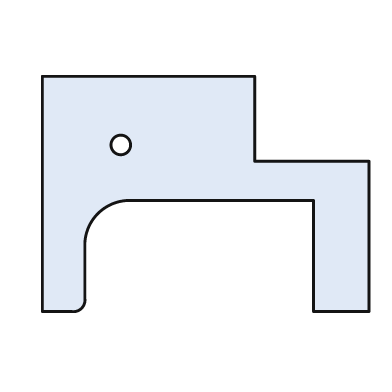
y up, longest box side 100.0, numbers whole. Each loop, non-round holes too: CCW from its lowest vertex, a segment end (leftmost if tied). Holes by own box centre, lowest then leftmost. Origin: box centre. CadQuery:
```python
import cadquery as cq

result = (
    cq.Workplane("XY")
    .moveTo(-50.0, -36.0)
    .lineTo(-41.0, -36.0)
    .threePointArc((-38.0, -35.0), (-37.0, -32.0))
    .lineTo(-37.0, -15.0)
    .threePointArc((-33.0, -6.0), (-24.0, -2.0))
    .lineTo(33.0, -2.0)
    .lineTo(33.0, -36.0)
    .lineTo(50.0, -36.0)
    .lineTo(50.0, 10.0)
    .lineTo(15.0, 10.0)
    .lineTo(15.0, 36.0)
    .lineTo(-50.0, 36.0)
    .close()
    .moveTo(-26.0, 15.0)
    .circle(3.0)
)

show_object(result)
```